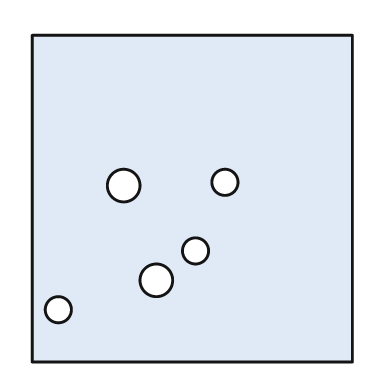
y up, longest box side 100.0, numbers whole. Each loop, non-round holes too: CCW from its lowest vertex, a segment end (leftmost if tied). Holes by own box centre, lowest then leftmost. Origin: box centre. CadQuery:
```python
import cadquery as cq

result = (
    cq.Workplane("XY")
    .moveTo(-49.0, -50.0)
    .lineTo(49.0, -50.0)
    .lineTo(49.0, 50.0)
    .lineTo(-49.0, 50.0)
    .close()
    .moveTo(-41.0, -34.0)
    .circle(4.0)
    .moveTo(-11.0, -25.0)
    .circle(5.0)
    .moveTo(1.0, -16.0)
    .circle(4.0)
    .moveTo(-21.0, 4.0)
    .circle(5.0)
    .moveTo(10.0, 5.0)
    .circle(4.0)
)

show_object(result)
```